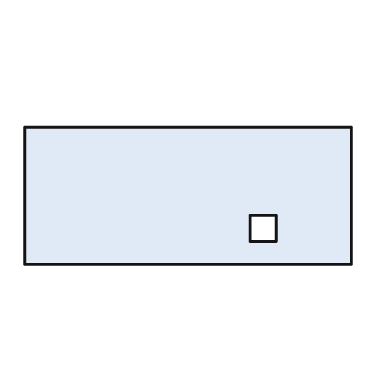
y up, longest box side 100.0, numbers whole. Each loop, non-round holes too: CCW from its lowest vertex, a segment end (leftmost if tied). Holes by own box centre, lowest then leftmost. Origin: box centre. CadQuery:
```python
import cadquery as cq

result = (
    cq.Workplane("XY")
    .moveTo(-50.0, -21.0)
    .lineTo(50.0, -21.0)
    .lineTo(50.0, 21.0)
    .lineTo(-50.0, 21.0)
    .close()
    .moveTo(19.0, -14.0)
    .lineTo(27.0, -14.0)
    .lineTo(27.0, -6.0)
    .lineTo(19.0, -6.0)
    .close()
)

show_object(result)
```